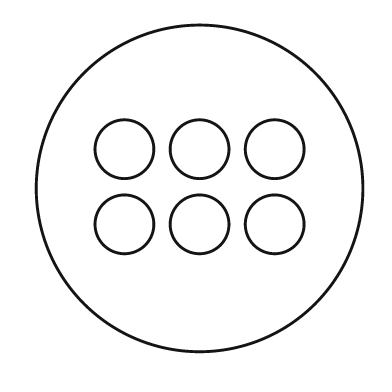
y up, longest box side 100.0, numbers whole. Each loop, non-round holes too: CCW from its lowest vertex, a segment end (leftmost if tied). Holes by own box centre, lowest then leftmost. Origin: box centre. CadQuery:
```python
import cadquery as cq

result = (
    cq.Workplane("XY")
    .moveTo(0.0, 0.0)
    .circle(50.0)
    .moveTo(-23.0, -11.0)
    .circle(9.0)
    .moveTo(0.0, -11.0)
    .circle(9.0)
    .moveTo(23.0, -11.0)
    .circle(9.0)
    .moveTo(-23.0, 12.0)
    .circle(9.0)
    .moveTo(0.0, 12.0)
    .circle(9.0)
    .moveTo(23.0, 12.0)
    .circle(9.0)
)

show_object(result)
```